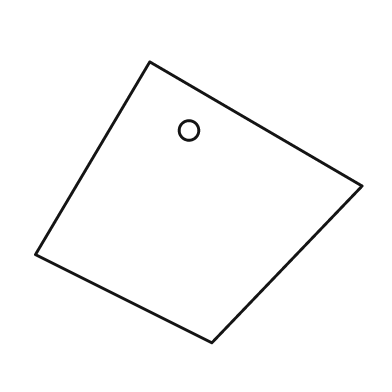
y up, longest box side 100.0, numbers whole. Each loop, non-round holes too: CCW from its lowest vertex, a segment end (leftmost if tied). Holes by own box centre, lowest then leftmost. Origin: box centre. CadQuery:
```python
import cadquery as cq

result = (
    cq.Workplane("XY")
    .moveTo(4.0, -43.0)
    .lineTo(50.0, 5.0)
    .lineTo(-15.0, 43.0)
    .lineTo(-50.0, -16.0)
    .close()
    .moveTo(-3.0, 22.0)
    .circle(3.0)
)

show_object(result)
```